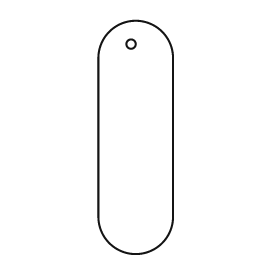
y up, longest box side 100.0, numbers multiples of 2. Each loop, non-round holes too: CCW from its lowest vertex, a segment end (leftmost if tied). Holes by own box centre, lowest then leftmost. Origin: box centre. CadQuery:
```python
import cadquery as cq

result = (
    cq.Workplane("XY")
    .moveTo(-16.0, -34.0)
    .threePointArc((0.0, -50.0), (16.0, -34.0))
    .lineTo(16.0, 34.0)
    .threePointArc((0.0, 50.0), (-16.0, 34.0))
    .close()
    .moveTo(-2.0, 40.0)
    .circle(2.0)
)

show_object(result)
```